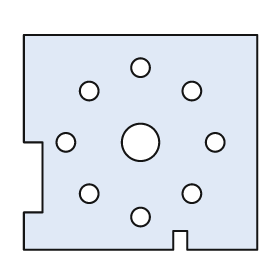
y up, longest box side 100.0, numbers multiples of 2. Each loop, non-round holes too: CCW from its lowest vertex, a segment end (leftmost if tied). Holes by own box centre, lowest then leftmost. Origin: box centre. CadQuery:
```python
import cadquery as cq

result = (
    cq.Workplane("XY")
    .moveTo(-50.0, -46.0)
    .lineTo(14.0, -46.0)
    .lineTo(14.0, -38.0)
    .lineTo(20.0, -38.0)
    .lineTo(20.0, -46.0)
    .lineTo(50.0, -46.0)
    .lineTo(50.0, 46.0)
    .lineTo(-50.0, 46.0)
    .lineTo(-50.0, 0.0)
    .lineTo(-42.0, 0.0)
    .lineTo(-42.0, -30.0)
    .lineTo(-50.0, -30.0)
    .close()
    .moveTo(0.0, -32.0)
    .circle(4.0)
    .moveTo(-22.0, -22.0)
    .circle(4.0)
    .moveTo(22.0, -22.0)
    .circle(4.0)
    .moveTo(-32.0, 0.0)
    .circle(4.0)
    .moveTo(0.0, 0.0)
    .circle(8.0)
    .moveTo(32.0, 0.0)
    .circle(4.0)
    .moveTo(-22.0, 22.0)
    .circle(4.0)
    .moveTo(22.0, 22.0)
    .circle(4.0)
    .moveTo(0.0, 32.0)
    .circle(4.0)
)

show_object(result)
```